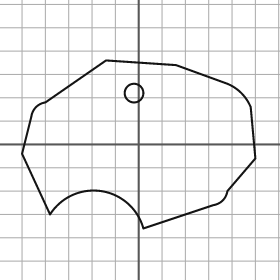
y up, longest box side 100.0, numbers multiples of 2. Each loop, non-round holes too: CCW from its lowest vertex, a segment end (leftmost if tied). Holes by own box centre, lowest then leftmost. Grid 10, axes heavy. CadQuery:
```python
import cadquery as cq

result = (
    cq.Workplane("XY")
    .moveTo(2.0, -36.0)
    .lineTo(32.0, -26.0)
    .threePointArc((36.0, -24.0), (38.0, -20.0))
    .lineTo(50.0, -6.0)
    .lineTo(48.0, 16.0)
    .threePointArc((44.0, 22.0), (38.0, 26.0))
    .lineTo(16.0, 34.0)
    .lineTo(-14.0, 36.0)
    .lineTo(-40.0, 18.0)
    .threePointArc((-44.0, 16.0), (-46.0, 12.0))
    .lineTo(-50.0, -4.0)
    .lineTo(-38.0, -30.0)
    .threePointArc((-16.0, -20.0), (2.0, -36.0))
    .close()
    .moveTo(-2.0, 22.0)
    .circle(4.0)
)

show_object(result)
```